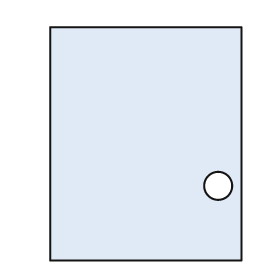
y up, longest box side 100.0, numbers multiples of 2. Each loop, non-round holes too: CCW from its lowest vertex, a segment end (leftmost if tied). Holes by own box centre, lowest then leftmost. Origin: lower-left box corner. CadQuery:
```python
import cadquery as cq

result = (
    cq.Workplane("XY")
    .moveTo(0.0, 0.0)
    .lineTo(82.0, 0.0)
    .lineTo(82.0, 100.0)
    .lineTo(0.0, 100.0)
    .close()
    .moveTo(72.0, 32.0)
    .circle(6.0)
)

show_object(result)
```